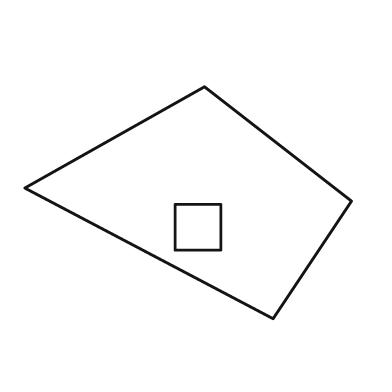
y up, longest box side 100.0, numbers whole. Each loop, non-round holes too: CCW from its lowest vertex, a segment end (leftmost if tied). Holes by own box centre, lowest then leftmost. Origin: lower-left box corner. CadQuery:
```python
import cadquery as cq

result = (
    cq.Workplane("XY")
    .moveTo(76.0, 0.0)
    .lineTo(100.0, 36.0)
    .lineTo(55.0, 71.0)
    .lineTo(0.0, 40.0)
    .close()
    .moveTo(46.0, 21.0)
    .lineTo(60.0, 21.0)
    .lineTo(60.0, 35.0)
    .lineTo(46.0, 35.0)
    .close()
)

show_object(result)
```